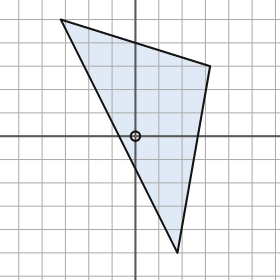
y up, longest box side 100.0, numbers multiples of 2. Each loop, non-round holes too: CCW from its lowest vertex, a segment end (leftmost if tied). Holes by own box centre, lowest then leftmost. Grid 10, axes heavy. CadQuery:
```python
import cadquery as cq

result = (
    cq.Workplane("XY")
    .moveTo(18.0, -50.0)
    .lineTo(32.0, 30.0)
    .lineTo(-32.0, 50.0)
    .close()
    .moveTo(0.0, 0.0)
    .circle(2.0)
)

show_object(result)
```